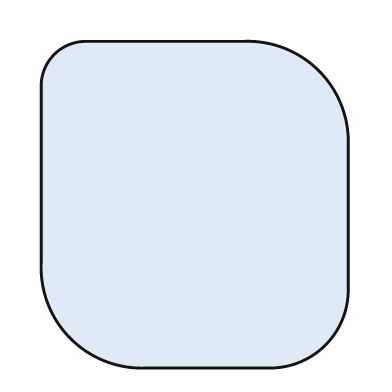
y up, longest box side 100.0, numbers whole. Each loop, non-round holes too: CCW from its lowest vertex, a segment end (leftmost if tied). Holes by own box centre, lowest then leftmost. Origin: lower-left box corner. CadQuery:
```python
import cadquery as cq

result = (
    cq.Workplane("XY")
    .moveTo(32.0, 0.0)
    .lineTo(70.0, 0.0)
    .threePointArc((87.0, 7.0), (94.0, 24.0))
    .lineTo(94.0, 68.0)
    .threePointArc((85.0, 91.0), (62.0, 100.0))
    .lineTo(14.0, 100.0)
    .threePointArc((4.0, 96.0), (0.0, 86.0))
    .lineTo(0.0, 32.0)
    .threePointArc((9.0, 9.0), (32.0, 0.0))
    .close()
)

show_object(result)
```